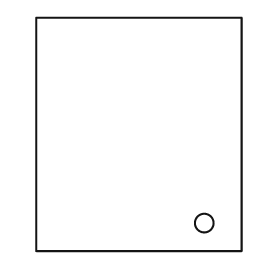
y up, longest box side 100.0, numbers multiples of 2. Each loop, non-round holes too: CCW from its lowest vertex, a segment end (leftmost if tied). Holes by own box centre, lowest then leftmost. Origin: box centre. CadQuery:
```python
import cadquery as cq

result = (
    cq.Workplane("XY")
    .moveTo(-44.0, -50.0)
    .lineTo(44.0, -50.0)
    .lineTo(44.0, 50.0)
    .lineTo(-44.0, 50.0)
    .close()
    .moveTo(28.0, -38.0)
    .circle(4.0)
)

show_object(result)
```